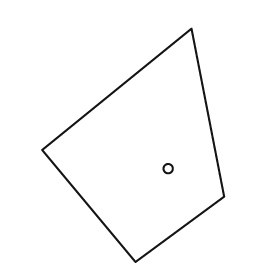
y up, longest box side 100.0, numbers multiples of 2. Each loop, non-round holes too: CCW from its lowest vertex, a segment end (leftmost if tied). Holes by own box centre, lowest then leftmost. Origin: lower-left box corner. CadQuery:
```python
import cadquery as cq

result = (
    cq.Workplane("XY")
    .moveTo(40.0, 0.0)
    .lineTo(78.0, 28.0)
    .lineTo(64.0, 100.0)
    .lineTo(0.0, 48.0)
    .close()
    .moveTo(54.0, 40.0)
    .circle(2.0)
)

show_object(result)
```